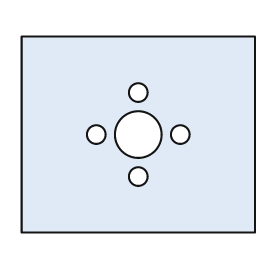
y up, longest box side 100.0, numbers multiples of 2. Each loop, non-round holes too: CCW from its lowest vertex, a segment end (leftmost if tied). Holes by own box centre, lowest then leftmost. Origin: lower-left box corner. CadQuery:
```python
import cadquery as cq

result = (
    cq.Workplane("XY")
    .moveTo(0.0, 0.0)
    .lineTo(100.0, 0.0)
    .lineTo(100.0, 84.0)
    .lineTo(0.0, 84.0)
    .close()
    .moveTo(50.0, 24.0)
    .circle(4.0)
    .moveTo(32.0, 42.0)
    .circle(4.0)
    .moveTo(50.0, 42.0)
    .circle(10.0)
    .moveTo(68.0, 42.0)
    .circle(4.0)
    .moveTo(50.0, 60.0)
    .circle(4.0)
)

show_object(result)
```